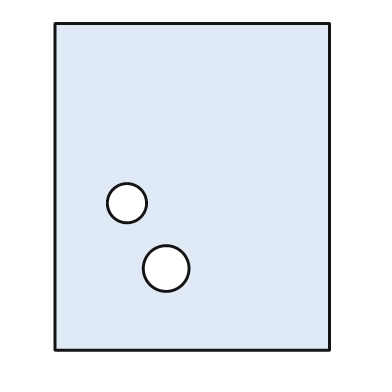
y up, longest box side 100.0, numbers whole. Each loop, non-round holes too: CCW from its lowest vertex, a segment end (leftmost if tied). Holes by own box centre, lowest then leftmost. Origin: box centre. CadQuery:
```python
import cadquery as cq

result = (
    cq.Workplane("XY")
    .moveTo(-42.0, -50.0)
    .lineTo(42.0, -50.0)
    .lineTo(42.0, 50.0)
    .lineTo(-42.0, 50.0)
    .close()
    .moveTo(-8.0, -25.0)
    .circle(7.0)
    .moveTo(-20.0, -5.0)
    .circle(6.0)
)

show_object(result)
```